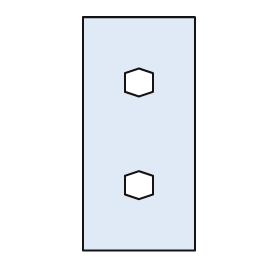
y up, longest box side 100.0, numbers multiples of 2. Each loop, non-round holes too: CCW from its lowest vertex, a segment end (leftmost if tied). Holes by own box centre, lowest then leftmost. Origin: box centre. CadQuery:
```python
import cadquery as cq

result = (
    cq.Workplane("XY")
    .moveTo(-24.0, -50.0)
    .lineTo(24.0, -50.0)
    .lineTo(24.0, 50.0)
    .lineTo(-24.0, 50.0)
    .close()
    .moveTo(0.0, -28.0)
    .lineTo(6.0, -26.0)
    .lineTo(6.0, -18.0)
    .lineTo(0.0, -16.0)
    .lineTo(-6.0, -18.0)
    .lineTo(-6.0, -26.0)
    .close()
    .moveTo(0.0, 16.0)
    .lineTo(6.0, 18.0)
    .lineTo(6.0, 26.0)
    .lineTo(0.0, 28.0)
    .lineTo(-6.0, 26.0)
    .lineTo(-6.0, 18.0)
    .close()
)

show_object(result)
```